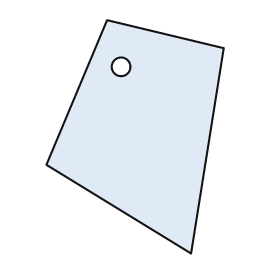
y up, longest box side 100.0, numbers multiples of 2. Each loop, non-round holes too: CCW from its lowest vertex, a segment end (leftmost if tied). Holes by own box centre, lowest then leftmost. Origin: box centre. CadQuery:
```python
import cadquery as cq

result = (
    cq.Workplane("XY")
    .moveTo(24.0, -50.0)
    .lineTo(38.0, 38.0)
    .lineTo(-12.0, 50.0)
    .lineTo(-38.0, -12.0)
    .close()
    .moveTo(-6.0, 30.0)
    .circle(4.0)
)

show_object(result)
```